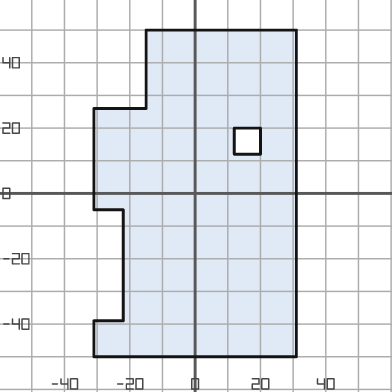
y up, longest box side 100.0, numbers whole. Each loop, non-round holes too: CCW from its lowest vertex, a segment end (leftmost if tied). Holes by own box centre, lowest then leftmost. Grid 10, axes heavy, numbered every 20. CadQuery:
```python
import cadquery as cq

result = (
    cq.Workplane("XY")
    .moveTo(-31.0, -50.0)
    .lineTo(31.0, -50.0)
    .lineTo(31.0, 50.0)
    .lineTo(-15.0, 50.0)
    .lineTo(-15.0, 26.0)
    .lineTo(-31.0, 26.0)
    .lineTo(-31.0, -5.0)
    .lineTo(-22.0, -5.0)
    .lineTo(-22.0, -39.0)
    .lineTo(-31.0, -39.0)
    .close()
    .moveTo(12.0, 12.0)
    .lineTo(20.0, 12.0)
    .lineTo(20.0, 20.0)
    .lineTo(12.0, 20.0)
    .close()
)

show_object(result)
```